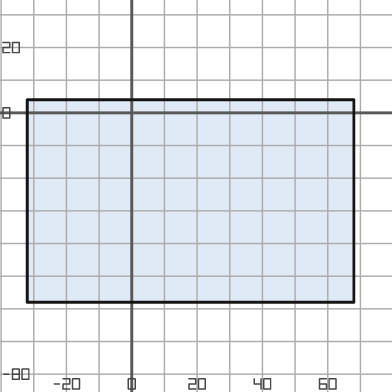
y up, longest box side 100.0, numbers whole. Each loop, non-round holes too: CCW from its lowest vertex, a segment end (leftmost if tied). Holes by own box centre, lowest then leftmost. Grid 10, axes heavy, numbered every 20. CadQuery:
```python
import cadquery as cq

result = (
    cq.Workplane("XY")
    .moveTo(-32.0, -58.0)
    .lineTo(68.0, -58.0)
    .lineTo(68.0, 4.0)
    .lineTo(-32.0, 4.0)
    .close()
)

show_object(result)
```